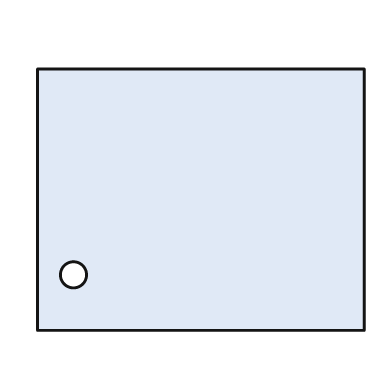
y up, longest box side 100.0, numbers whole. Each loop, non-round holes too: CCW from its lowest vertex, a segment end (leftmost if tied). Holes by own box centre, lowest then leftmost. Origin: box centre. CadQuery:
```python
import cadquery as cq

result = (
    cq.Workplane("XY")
    .moveTo(-50.0, -40.0)
    .lineTo(50.0, -40.0)
    .lineTo(50.0, 40.0)
    .lineTo(-50.0, 40.0)
    .close()
    .moveTo(-39.0, -23.0)
    .circle(4.0)
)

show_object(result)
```